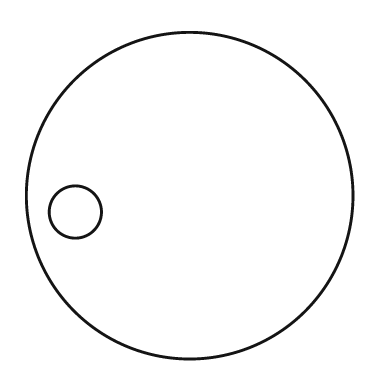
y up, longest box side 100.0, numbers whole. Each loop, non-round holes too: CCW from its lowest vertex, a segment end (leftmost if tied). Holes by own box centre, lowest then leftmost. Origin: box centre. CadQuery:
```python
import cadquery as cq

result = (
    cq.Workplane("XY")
    .moveTo(0.0, 0.0)
    .circle(50.0)
    .moveTo(-35.0, -5.0)
    .circle(8.0)
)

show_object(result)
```